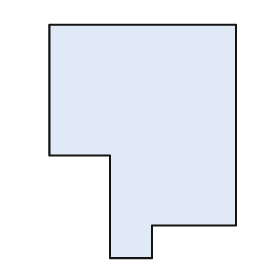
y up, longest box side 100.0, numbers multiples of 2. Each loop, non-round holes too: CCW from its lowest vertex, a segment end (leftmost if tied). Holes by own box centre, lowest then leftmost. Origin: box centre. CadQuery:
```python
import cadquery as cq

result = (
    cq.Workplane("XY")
    .moveTo(-14.0, -50.0)
    .lineTo(4.0, -50.0)
    .lineTo(4.0, -36.0)
    .lineTo(40.0, -36.0)
    .lineTo(40.0, 50.0)
    .lineTo(-40.0, 50.0)
    .lineTo(-40.0, -6.0)
    .lineTo(-14.0, -6.0)
    .close()
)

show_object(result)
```